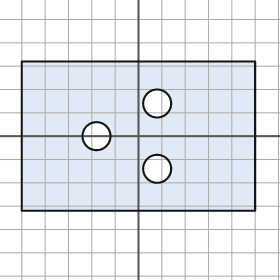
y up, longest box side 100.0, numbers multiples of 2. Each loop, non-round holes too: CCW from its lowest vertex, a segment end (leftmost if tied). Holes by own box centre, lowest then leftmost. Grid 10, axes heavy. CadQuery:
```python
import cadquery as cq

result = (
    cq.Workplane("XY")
    .moveTo(-50.0, -32.0)
    .lineTo(50.0, -32.0)
    .lineTo(50.0, 32.0)
    .lineTo(-50.0, 32.0)
    .close()
    .moveTo(8.0, -14.0)
    .circle(6.0)
    .moveTo(-18.0, 0.0)
    .circle(6.0)
    .moveTo(8.0, 14.0)
    .circle(6.0)
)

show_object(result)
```